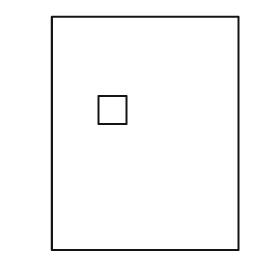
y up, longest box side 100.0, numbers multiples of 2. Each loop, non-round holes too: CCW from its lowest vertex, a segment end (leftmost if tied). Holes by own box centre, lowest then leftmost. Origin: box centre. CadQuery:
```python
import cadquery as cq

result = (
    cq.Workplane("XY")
    .moveTo(-40.0, -50.0)
    .lineTo(40.0, -50.0)
    .lineTo(40.0, 50.0)
    .lineTo(-40.0, 50.0)
    .close()
    .moveTo(-20.0, 4.0)
    .lineTo(-8.0, 4.0)
    .lineTo(-8.0, 16.0)
    .lineTo(-20.0, 16.0)
    .close()
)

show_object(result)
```